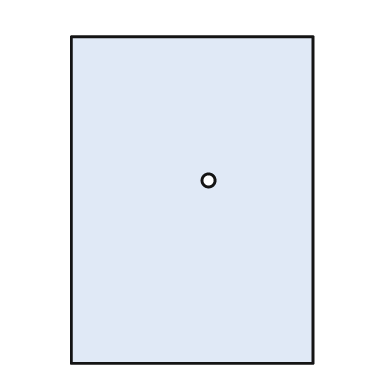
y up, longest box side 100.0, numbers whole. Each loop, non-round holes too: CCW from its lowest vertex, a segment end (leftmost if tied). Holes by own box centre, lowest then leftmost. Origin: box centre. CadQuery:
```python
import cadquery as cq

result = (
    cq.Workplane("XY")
    .moveTo(-37.0, -50.0)
    .lineTo(37.0, -50.0)
    .lineTo(37.0, 50.0)
    .lineTo(-37.0, 50.0)
    .close()
    .moveTo(5.0, 6.0)
    .circle(2.0)
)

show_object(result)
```